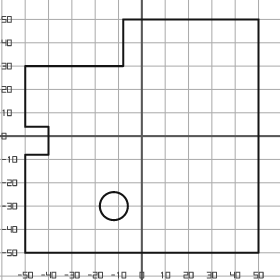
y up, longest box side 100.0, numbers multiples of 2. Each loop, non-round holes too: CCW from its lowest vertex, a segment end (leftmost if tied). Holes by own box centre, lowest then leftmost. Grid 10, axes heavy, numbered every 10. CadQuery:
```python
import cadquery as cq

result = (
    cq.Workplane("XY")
    .moveTo(-50.0, -50.0)
    .lineTo(50.0, -50.0)
    .lineTo(50.0, 50.0)
    .lineTo(-8.0, 50.0)
    .lineTo(-8.0, 30.0)
    .lineTo(-50.0, 30.0)
    .lineTo(-50.0, 4.0)
    .lineTo(-40.0, 4.0)
    .lineTo(-40.0, -8.0)
    .lineTo(-50.0, -8.0)
    .close()
    .moveTo(-12.0, -30.0)
    .circle(6.0)
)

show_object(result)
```